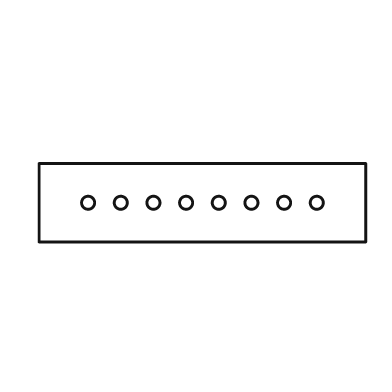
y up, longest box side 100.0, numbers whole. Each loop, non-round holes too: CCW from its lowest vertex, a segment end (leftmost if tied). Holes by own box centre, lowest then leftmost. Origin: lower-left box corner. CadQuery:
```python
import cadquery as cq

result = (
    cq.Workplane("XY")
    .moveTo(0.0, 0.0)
    .lineTo(100.0, 0.0)
    .lineTo(100.0, 24.0)
    .lineTo(0.0, 24.0)
    .close()
    .moveTo(15.0, 12.0)
    .circle(2.0)
    .moveTo(25.0, 12.0)
    .circle(2.0)
    .moveTo(35.0, 12.0)
    .circle(2.0)
    .moveTo(45.0, 12.0)
    .circle(2.0)
    .moveTo(55.0, 12.0)
    .circle(2.0)
    .moveTo(65.0, 12.0)
    .circle(2.0)
    .moveTo(75.0, 12.0)
    .circle(2.0)
    .moveTo(85.0, 12.0)
    .circle(2.0)
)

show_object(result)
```